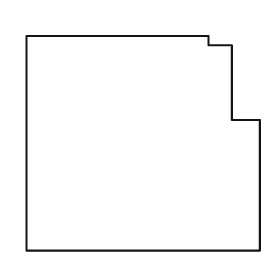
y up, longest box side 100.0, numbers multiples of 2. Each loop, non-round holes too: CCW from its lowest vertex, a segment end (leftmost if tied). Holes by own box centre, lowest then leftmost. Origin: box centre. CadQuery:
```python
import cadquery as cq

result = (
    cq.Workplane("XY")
    .moveTo(-50.0, -46.0)
    .lineTo(50.0, -46.0)
    .lineTo(50.0, 10.0)
    .lineTo(38.0, 10.0)
    .lineTo(38.0, 42.0)
    .lineTo(28.0, 42.0)
    .lineTo(28.0, 46.0)
    .lineTo(-50.0, 46.0)
    .close()
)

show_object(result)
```